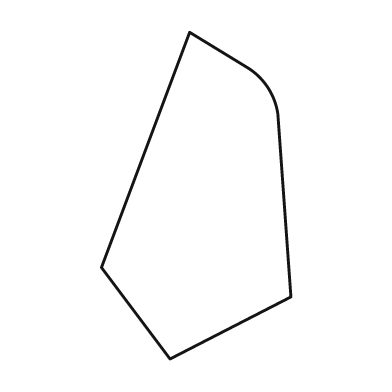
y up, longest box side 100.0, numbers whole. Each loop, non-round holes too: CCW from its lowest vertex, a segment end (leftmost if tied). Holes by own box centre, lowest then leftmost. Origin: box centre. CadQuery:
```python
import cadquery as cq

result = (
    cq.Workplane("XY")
    .moveTo(-8.0, -50.0)
    .lineTo(29.0, -31.0)
    .lineTo(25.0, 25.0)
    .threePointArc((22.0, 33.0), (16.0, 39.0))
    .lineTo(-2.0, 50.0)
    .lineTo(-29.0, -22.0)
    .close()
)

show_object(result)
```